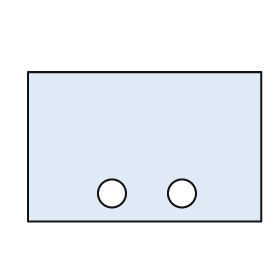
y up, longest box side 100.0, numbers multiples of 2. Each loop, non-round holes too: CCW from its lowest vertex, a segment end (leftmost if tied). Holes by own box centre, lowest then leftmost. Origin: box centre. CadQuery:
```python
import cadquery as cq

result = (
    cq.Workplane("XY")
    .moveTo(-50.0, -32.0)
    .lineTo(50.0, -32.0)
    .lineTo(50.0, 32.0)
    .lineTo(-50.0, 32.0)
    .close()
    .moveTo(-14.0, -20.0)
    .circle(6.0)
    .moveTo(16.0, -20.0)
    .circle(6.0)
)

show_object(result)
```